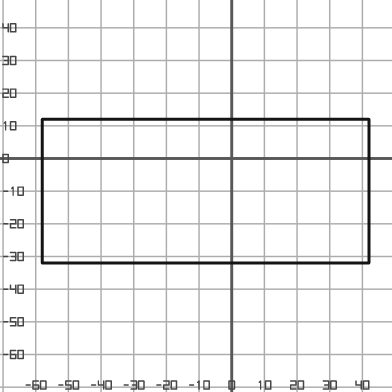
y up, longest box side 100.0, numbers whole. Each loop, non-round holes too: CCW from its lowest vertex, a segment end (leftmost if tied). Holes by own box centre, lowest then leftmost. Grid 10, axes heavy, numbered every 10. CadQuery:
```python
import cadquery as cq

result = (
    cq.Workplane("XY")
    .moveTo(-58.0, -32.0)
    .lineTo(42.0, -32.0)
    .lineTo(42.0, 12.0)
    .lineTo(-58.0, 12.0)
    .close()
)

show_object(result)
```